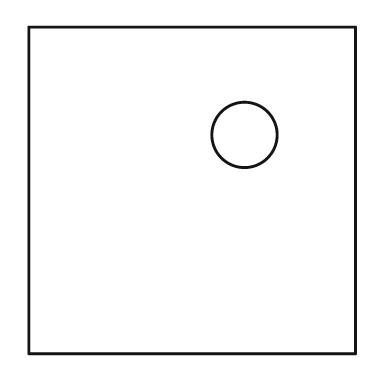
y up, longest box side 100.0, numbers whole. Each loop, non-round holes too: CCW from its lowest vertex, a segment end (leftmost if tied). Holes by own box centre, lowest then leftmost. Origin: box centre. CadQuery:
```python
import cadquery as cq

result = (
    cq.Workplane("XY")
    .moveTo(-50.0, -50.0)
    .lineTo(50.0, -50.0)
    .lineTo(50.0, 50.0)
    .lineTo(-50.0, 50.0)
    .close()
    .moveTo(16.0, 17.0)
    .circle(10.0)
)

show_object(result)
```